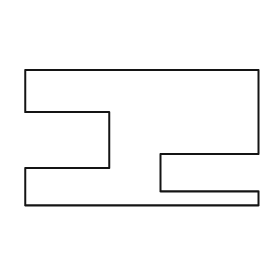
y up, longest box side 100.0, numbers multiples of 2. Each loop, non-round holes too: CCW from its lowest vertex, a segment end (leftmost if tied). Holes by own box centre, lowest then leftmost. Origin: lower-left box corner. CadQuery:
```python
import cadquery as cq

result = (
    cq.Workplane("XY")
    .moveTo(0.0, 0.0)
    .lineTo(100.0, 0.0)
    .lineTo(100.0, 6.0)
    .lineTo(58.0, 6.0)
    .lineTo(58.0, 22.0)
    .lineTo(100.0, 22.0)
    .lineTo(100.0, 58.0)
    .lineTo(0.0, 58.0)
    .lineTo(0.0, 40.0)
    .lineTo(36.0, 40.0)
    .lineTo(36.0, 16.0)
    .lineTo(0.0, 16.0)
    .close()
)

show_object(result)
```